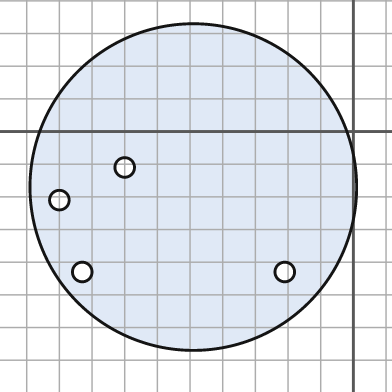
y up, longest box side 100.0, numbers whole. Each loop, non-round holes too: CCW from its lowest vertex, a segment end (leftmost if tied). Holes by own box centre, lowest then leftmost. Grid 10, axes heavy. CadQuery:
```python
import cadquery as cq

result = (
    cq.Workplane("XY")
    .moveTo(-49.0, -17.0)
    .circle(50.0)
    .moveTo(-83.0, -43.0)
    .circle(3.0)
    .moveTo(-21.0, -43.0)
    .circle(3.0)
    .moveTo(-90.0, -21.0)
    .circle(3.0)
    .moveTo(-70.0, -11.0)
    .circle(3.0)
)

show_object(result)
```